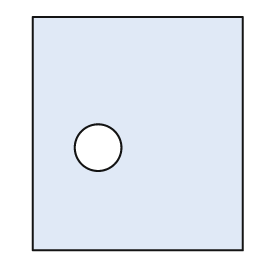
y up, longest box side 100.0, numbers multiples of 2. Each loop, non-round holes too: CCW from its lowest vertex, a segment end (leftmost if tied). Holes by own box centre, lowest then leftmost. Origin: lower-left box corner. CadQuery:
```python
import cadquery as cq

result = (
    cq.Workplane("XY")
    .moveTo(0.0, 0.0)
    .lineTo(90.0, 0.0)
    .lineTo(90.0, 100.0)
    .lineTo(0.0, 100.0)
    .close()
    .moveTo(28.0, 44.0)
    .circle(10.0)
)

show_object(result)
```